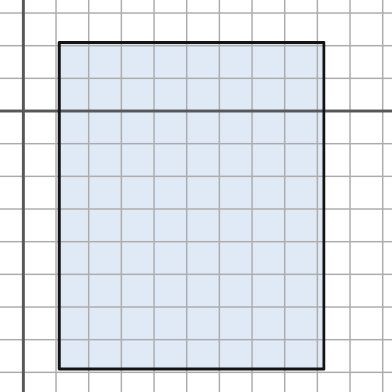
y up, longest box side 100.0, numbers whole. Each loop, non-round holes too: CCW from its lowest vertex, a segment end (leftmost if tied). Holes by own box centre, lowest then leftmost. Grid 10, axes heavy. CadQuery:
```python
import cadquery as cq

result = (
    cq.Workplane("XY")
    .moveTo(11.0, -79.0)
    .lineTo(92.0, -79.0)
    .lineTo(92.0, 21.0)
    .lineTo(11.0, 21.0)
    .close()
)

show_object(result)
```